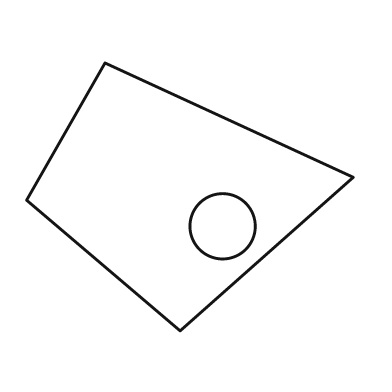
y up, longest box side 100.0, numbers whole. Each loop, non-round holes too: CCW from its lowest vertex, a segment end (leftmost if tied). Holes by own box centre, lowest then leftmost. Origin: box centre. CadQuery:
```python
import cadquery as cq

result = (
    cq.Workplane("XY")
    .moveTo(-3.0, -41.0)
    .lineTo(50.0, 6.0)
    .lineTo(-26.0, 41.0)
    .lineTo(-50.0, -1.0)
    .close()
    .moveTo(10.0, -9.0)
    .circle(10.0)
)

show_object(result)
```